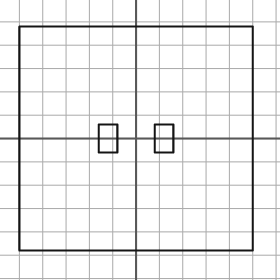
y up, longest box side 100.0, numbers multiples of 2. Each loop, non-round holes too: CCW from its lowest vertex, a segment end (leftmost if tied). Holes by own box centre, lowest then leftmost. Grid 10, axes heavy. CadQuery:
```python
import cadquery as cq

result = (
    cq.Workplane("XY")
    .moveTo(-50.0, -48.0)
    .lineTo(50.0, -48.0)
    .lineTo(50.0, 48.0)
    .lineTo(-50.0, 48.0)
    .close()
    .moveTo(-16.0, -6.0)
    .lineTo(-8.0, -6.0)
    .lineTo(-8.0, 6.0)
    .lineTo(-16.0, 6.0)
    .close()
    .moveTo(8.0, -6.0)
    .lineTo(16.0, -6.0)
    .lineTo(16.0, 6.0)
    .lineTo(8.0, 6.0)
    .close()
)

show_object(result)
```